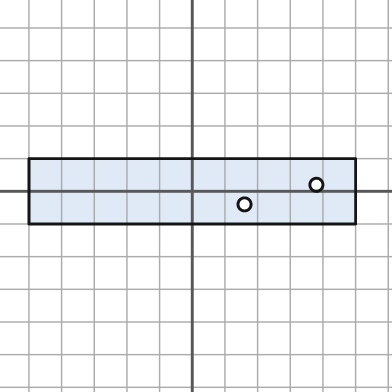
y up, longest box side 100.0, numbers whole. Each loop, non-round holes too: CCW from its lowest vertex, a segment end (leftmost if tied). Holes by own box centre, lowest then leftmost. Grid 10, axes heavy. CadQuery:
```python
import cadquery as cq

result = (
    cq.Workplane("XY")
    .moveTo(-50.0, -10.0)
    .lineTo(50.0, -10.0)
    .lineTo(50.0, 10.0)
    .lineTo(-50.0, 10.0)
    .close()
    .moveTo(16.0, -4.0)
    .circle(2.0)
    .moveTo(38.0, 2.0)
    .circle(2.0)
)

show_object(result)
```